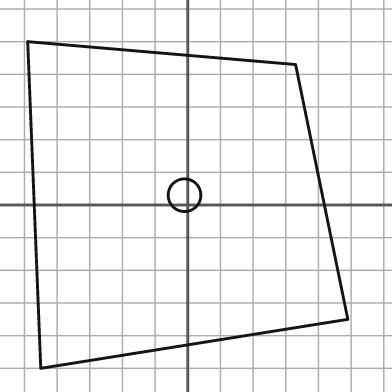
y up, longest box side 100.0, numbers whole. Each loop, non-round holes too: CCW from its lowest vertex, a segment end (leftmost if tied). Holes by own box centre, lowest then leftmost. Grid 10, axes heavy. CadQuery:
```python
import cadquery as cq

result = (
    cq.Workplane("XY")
    .moveTo(-45.0, -50.0)
    .lineTo(49.0, -35.0)
    .lineTo(33.0, 43.0)
    .lineTo(-49.0, 50.0)
    .close()
    .moveTo(-1.0, 3.0)
    .circle(5.0)
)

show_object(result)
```